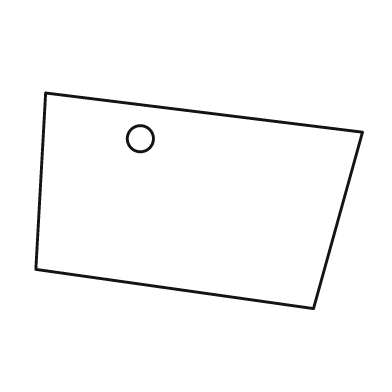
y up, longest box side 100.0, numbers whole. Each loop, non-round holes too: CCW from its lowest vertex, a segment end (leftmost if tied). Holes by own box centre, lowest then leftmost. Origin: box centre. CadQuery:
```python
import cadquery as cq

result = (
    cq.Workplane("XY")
    .moveTo(35.0, -33.0)
    .lineTo(50.0, 21.0)
    .lineTo(-47.0, 33.0)
    .lineTo(-50.0, -21.0)
    .close()
    .moveTo(-18.0, 19.0)
    .circle(4.0)
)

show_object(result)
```